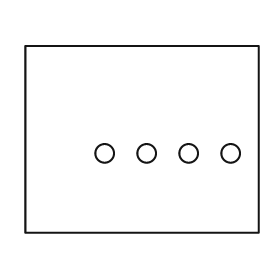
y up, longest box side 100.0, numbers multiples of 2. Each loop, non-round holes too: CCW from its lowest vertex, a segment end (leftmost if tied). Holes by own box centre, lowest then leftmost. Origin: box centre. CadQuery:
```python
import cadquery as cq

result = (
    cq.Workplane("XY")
    .moveTo(-50.0, -40.0)
    .lineTo(50.0, -40.0)
    .lineTo(50.0, 40.0)
    .lineTo(-50.0, 40.0)
    .close()
    .moveTo(-16.0, -6.0)
    .circle(4.0)
    .moveTo(2.0, -6.0)
    .circle(4.0)
    .moveTo(20.0, -6.0)
    .circle(4.0)
    .moveTo(38.0, -6.0)
    .circle(4.0)
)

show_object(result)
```